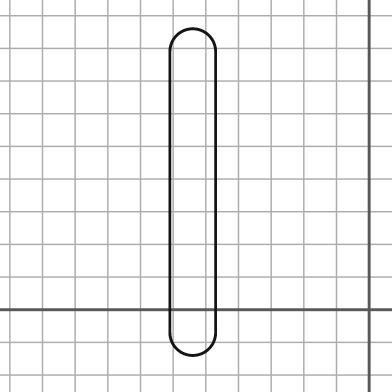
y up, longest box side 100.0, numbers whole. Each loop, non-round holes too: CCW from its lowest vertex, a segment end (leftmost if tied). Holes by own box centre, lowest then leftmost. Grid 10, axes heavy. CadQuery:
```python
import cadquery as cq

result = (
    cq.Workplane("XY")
    .moveTo(-61.0, -7.0)
    .threePointArc((-54.0, -14.0), (-47.0, -7.0))
    .lineTo(-47.0, 79.0)
    .threePointArc((-54.0, 86.0), (-61.0, 79.0))
    .close()
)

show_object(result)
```